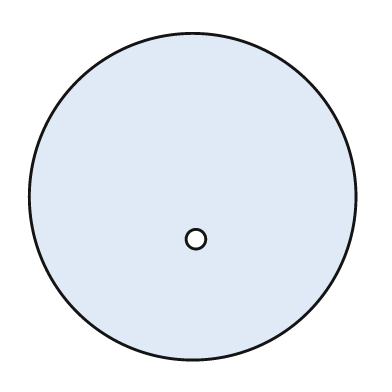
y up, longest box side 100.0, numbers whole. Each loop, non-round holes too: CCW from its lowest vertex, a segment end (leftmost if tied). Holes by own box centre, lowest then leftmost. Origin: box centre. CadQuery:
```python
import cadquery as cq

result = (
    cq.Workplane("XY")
    .moveTo(0.0, 0.0)
    .circle(50.0)
    .moveTo(1.0, -13.0)
    .circle(3.0)
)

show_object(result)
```